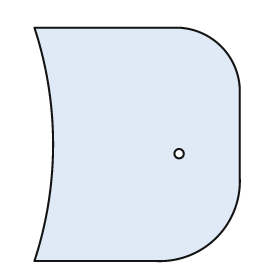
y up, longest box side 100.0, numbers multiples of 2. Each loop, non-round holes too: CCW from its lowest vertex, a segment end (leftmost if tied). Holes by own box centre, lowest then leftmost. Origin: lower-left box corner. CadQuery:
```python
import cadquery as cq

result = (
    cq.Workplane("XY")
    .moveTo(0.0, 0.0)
    .lineTo(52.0, 0.0)
    .threePointArc((78.0, 10.0), (88.0, 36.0))
    .lineTo(88.0, 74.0)
    .threePointArc((80.0, 92.0), (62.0, 100.0))
    .lineTo(0.0, 100.0)
    .threePointArc((8.0, 50.0), (0.0, 0.0))
    .close()
    .moveTo(62.0, 46.0)
    .circle(2.0)
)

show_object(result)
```